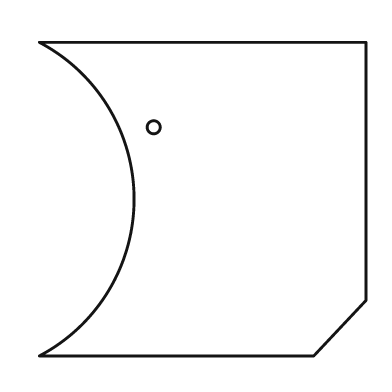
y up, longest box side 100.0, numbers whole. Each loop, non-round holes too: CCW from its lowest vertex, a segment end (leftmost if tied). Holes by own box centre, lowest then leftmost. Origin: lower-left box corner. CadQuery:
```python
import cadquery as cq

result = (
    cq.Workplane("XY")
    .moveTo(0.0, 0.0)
    .lineTo(84.0, 0.0)
    .lineTo(100.0, 17.0)
    .lineTo(100.0, 96.0)
    .lineTo(0.0, 96.0)
    .threePointArc((29.0, 48.0), (0.0, 0.0))
    .close()
    .moveTo(35.0, 70.0)
    .circle(2.0)
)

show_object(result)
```